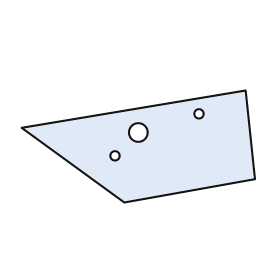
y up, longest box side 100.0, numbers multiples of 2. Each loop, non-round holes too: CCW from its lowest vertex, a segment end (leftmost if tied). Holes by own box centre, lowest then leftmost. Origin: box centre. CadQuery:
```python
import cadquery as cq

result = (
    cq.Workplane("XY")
    .moveTo(-6.0, -24.0)
    .lineTo(50.0, -14.0)
    .lineTo(46.0, 24.0)
    .lineTo(-50.0, 8.0)
    .close()
    .moveTo(-10.0, -4.0)
    .circle(2.0)
    .moveTo(0.0, 6.0)
    .circle(4.0)
    .moveTo(26.0, 14.0)
    .circle(2.0)
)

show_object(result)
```